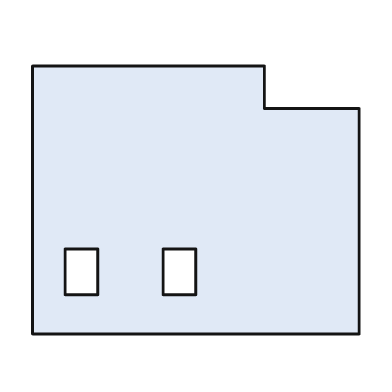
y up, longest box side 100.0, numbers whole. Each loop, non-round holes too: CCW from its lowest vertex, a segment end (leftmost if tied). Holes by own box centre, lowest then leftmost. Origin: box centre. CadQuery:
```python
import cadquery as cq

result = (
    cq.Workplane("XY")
    .moveTo(-50.0, -41.0)
    .lineTo(50.0, -41.0)
    .lineTo(50.0, 28.0)
    .lineTo(21.0, 28.0)
    .lineTo(21.0, 41.0)
    .lineTo(-50.0, 41.0)
    .close()
    .moveTo(-40.0, -29.0)
    .lineTo(-30.0, -29.0)
    .lineTo(-30.0, -15.0)
    .lineTo(-40.0, -15.0)
    .close()
    .moveTo(-10.0, -29.0)
    .lineTo(0.0, -29.0)
    .lineTo(0.0, -15.0)
    .lineTo(-10.0, -15.0)
    .close()
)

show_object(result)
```